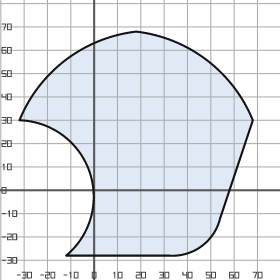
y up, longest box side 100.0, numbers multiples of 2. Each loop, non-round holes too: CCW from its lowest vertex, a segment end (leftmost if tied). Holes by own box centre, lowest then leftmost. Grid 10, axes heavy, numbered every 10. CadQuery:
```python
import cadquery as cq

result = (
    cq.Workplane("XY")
    .moveTo(-12.0, -28.0)
    .lineTo(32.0, -28.0)
    .threePointArc((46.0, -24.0), (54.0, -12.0))
    .lineTo(68.0, 30.0)
    .threePointArc((48.0, 56.0), (18.0, 68.0))
    .threePointArc((-12.0, 56.0), (-32.0, 30.0))
    .threePointArc((-2.0, 8.0), (-12.0, -28.0))
    .close()
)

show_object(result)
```